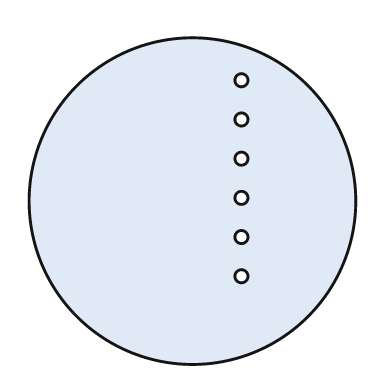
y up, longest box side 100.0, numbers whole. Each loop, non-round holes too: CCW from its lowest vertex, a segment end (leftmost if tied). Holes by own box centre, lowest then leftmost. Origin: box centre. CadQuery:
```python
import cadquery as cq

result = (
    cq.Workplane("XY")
    .moveTo(0.0, 0.0)
    .circle(50.0)
    .moveTo(15.0, -23.0)
    .circle(2.0)
    .moveTo(15.0, -11.0)
    .circle(2.0)
    .moveTo(15.0, 1.0)
    .circle(2.0)
    .moveTo(15.0, 13.0)
    .circle(2.0)
    .moveTo(15.0, 25.0)
    .circle(2.0)
    .moveTo(15.0, 37.0)
    .circle(2.0)
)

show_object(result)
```